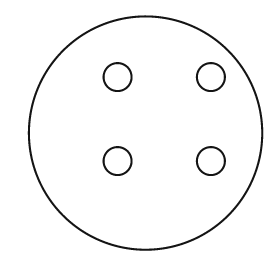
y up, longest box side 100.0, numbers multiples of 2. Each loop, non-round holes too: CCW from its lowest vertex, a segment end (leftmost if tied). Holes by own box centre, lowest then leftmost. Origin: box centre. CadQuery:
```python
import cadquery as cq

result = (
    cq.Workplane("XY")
    .moveTo(0.0, 0.0)
    .circle(50.0)
    .moveTo(-12.0, -12.0)
    .circle(6.0)
    .moveTo(28.0, -12.0)
    .circle(6.0)
    .moveTo(-12.0, 24.0)
    .circle(6.0)
    .moveTo(28.0, 24.0)
    .circle(6.0)
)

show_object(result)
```